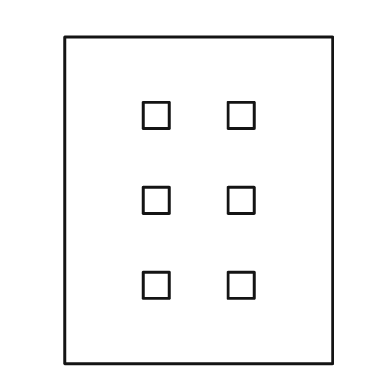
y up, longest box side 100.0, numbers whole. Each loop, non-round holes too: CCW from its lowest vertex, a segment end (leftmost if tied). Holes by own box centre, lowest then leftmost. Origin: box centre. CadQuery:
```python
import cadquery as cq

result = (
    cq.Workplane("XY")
    .moveTo(-41.0, -50.0)
    .lineTo(41.0, -50.0)
    .lineTo(41.0, 50.0)
    .lineTo(-41.0, 50.0)
    .close()
    .moveTo(-17.0, -30.0)
    .lineTo(-9.0, -30.0)
    .lineTo(-9.0, -22.0)
    .lineTo(-17.0, -22.0)
    .close()
    .moveTo(9.0, -30.0)
    .lineTo(17.0, -30.0)
    .lineTo(17.0, -22.0)
    .lineTo(9.0, -22.0)
    .close()
    .moveTo(-17.0, -4.0)
    .lineTo(-9.0, -4.0)
    .lineTo(-9.0, 4.0)
    .lineTo(-17.0, 4.0)
    .close()
    .moveTo(9.0, -4.0)
    .lineTo(17.0, -4.0)
    .lineTo(17.0, 4.0)
    .lineTo(9.0, 4.0)
    .close()
    .moveTo(-17.0, 22.0)
    .lineTo(-9.0, 22.0)
    .lineTo(-9.0, 30.0)
    .lineTo(-17.0, 30.0)
    .close()
    .moveTo(9.0, 22.0)
    .lineTo(17.0, 22.0)
    .lineTo(17.0, 30.0)
    .lineTo(9.0, 30.0)
    .close()
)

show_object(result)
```